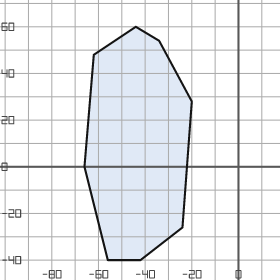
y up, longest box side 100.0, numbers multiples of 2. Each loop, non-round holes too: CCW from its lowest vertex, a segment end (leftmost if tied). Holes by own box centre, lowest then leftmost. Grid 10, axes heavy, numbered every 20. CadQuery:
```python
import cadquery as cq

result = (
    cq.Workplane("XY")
    .moveTo(-56.0, -40.0)
    .lineTo(-42.0, -40.0)
    .lineTo(-24.0, -26.0)
    .lineTo(-20.0, 28.0)
    .lineTo(-34.0, 54.0)
    .lineTo(-44.0, 60.0)
    .lineTo(-62.0, 48.0)
    .lineTo(-66.0, 0.0)
    .close()
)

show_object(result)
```